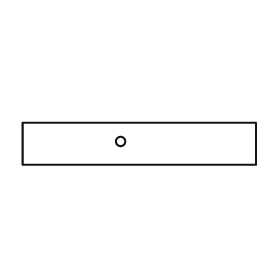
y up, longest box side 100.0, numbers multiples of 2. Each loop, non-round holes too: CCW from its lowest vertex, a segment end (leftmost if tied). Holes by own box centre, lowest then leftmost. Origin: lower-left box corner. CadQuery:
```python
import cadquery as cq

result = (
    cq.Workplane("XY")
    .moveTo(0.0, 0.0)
    .lineTo(100.0, 0.0)
    .lineTo(100.0, 18.0)
    .lineTo(0.0, 18.0)
    .close()
    .moveTo(42.0, 10.0)
    .circle(2.0)
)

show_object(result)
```